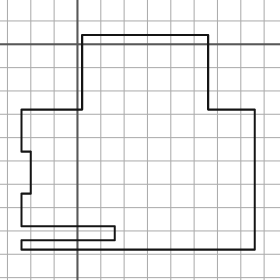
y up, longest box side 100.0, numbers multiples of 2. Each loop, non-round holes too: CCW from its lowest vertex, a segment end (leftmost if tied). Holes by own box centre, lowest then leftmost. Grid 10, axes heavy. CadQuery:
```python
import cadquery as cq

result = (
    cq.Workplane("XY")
    .moveTo(-24.0, -88.0)
    .lineTo(76.0, -88.0)
    .lineTo(76.0, -28.0)
    .lineTo(56.0, -28.0)
    .lineTo(56.0, 4.0)
    .lineTo(2.0, 4.0)
    .lineTo(2.0, -28.0)
    .lineTo(-24.0, -28.0)
    .lineTo(-24.0, -46.0)
    .lineTo(-20.0, -46.0)
    .lineTo(-20.0, -64.0)
    .lineTo(-24.0, -64.0)
    .lineTo(-24.0, -78.0)
    .lineTo(16.0, -78.0)
    .lineTo(16.0, -84.0)
    .lineTo(-24.0, -84.0)
    .close()
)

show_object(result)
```